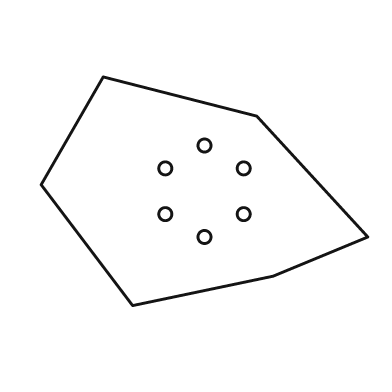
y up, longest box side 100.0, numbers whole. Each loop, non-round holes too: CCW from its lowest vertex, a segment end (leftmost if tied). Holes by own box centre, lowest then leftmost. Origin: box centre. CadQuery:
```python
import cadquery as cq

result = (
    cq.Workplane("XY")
    .moveTo(-22.0, -35.0)
    .lineTo(21.0, -26.0)
    .lineTo(50.0, -14.0)
    .lineTo(16.0, 23.0)
    .lineTo(-31.0, 35.0)
    .lineTo(-50.0, 2.0)
    .close()
    .moveTo(0.0, -14.0)
    .circle(2.0)
    .moveTo(-12.0, -7.0)
    .circle(2.0)
    .moveTo(12.0, -7.0)
    .circle(2.0)
    .moveTo(-12.0, 7.0)
    .circle(2.0)
    .moveTo(12.0, 7.0)
    .circle(2.0)
    .moveTo(0.0, 14.0)
    .circle(2.0)
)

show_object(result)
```